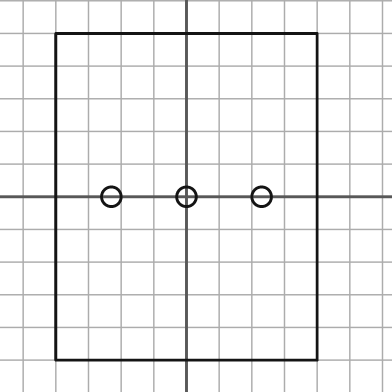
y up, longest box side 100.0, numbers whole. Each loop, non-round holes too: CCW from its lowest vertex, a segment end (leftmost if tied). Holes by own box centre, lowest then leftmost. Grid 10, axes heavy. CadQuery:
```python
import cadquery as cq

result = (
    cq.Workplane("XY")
    .moveTo(-40.0, -50.0)
    .lineTo(40.0, -50.0)
    .lineTo(40.0, 50.0)
    .lineTo(-40.0, 50.0)
    .close()
    .moveTo(-23.0, 0.0)
    .circle(3.0)
    .moveTo(0.0, 0.0)
    .circle(3.0)
    .moveTo(23.0, 0.0)
    .circle(3.0)
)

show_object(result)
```